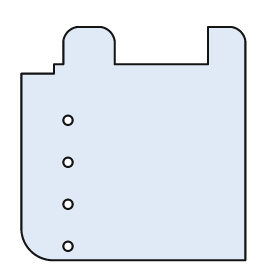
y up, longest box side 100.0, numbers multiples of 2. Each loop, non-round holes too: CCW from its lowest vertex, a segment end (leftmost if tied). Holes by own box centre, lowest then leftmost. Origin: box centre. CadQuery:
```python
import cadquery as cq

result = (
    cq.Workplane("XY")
    .moveTo(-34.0, -50.0)
    .lineTo(48.0, -50.0)
    .lineTo(48.0, 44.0)
    .threePointArc((46.0, 48.0), (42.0, 50.0))
    .lineTo(32.0, 50.0)
    .lineTo(32.0, 34.0)
    .lineTo(-8.0, 34.0)
    .lineTo(-8.0, 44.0)
    .threePointArc((-10.0, 48.0), (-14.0, 50.0))
    .lineTo(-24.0, 50.0)
    .threePointArc((-28.0, 48.0), (-30.0, 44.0))
    .lineTo(-30.0, 34.0)
    .lineTo(-34.0, 34.0)
    .lineTo(-34.0, 30.0)
    .lineTo(-48.0, 30.0)
    .lineTo(-48.0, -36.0)
    .threePointArc((-44.0, -46.0), (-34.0, -50.0))
    .close()
    .moveTo(-28.0, -44.0)
    .circle(2.0)
    .moveTo(-28.0, -26.0)
    .circle(2.0)
    .moveTo(-28.0, -8.0)
    .circle(2.0)
    .moveTo(-28.0, 10.0)
    .circle(2.0)
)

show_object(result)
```